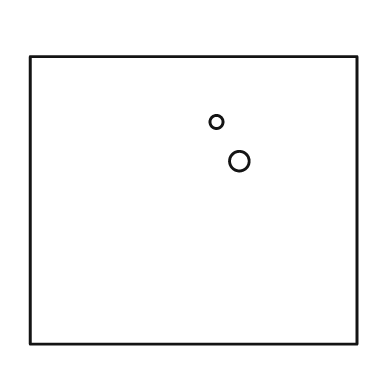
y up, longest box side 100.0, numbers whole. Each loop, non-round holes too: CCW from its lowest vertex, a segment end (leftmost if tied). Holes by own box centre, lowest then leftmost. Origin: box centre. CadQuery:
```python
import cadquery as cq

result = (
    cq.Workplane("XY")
    .moveTo(-50.0, -44.0)
    .lineTo(50.0, -44.0)
    .lineTo(50.0, 44.0)
    .lineTo(-50.0, 44.0)
    .close()
    .moveTo(14.0, 12.0)
    .circle(3.0)
    .moveTo(7.0, 24.0)
    .circle(2.0)
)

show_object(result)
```